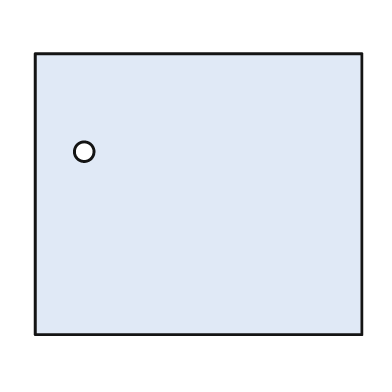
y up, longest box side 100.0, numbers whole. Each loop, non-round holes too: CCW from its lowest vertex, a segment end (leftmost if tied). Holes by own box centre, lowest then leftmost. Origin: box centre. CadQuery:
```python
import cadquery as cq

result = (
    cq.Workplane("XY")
    .moveTo(-50.0, -43.0)
    .lineTo(50.0, -43.0)
    .lineTo(50.0, 43.0)
    .lineTo(-50.0, 43.0)
    .close()
    .moveTo(-35.0, 13.0)
    .circle(3.0)
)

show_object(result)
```